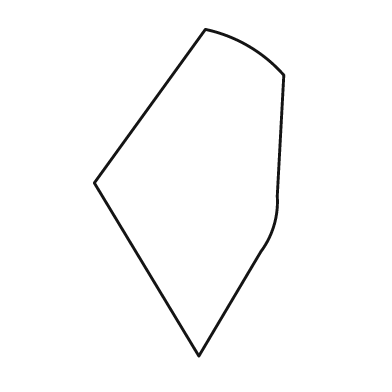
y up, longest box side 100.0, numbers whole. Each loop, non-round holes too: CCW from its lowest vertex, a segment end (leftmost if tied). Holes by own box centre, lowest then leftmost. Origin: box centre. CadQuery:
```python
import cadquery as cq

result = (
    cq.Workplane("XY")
    .moveTo(3.0, -50.0)
    .lineTo(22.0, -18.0)
    .threePointArc((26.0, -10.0), (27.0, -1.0))
    .lineTo(29.0, 36.0)
    .threePointArc((18.0, 45.0), (5.0, 50.0))
    .lineTo(-29.0, 3.0)
    .close()
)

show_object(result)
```